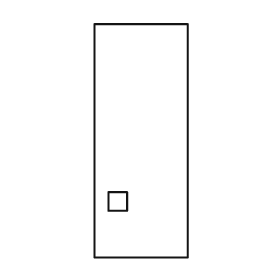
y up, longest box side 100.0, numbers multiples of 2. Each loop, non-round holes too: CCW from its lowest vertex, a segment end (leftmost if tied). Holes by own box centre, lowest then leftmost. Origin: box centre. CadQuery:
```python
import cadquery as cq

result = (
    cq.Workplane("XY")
    .moveTo(-20.0, -50.0)
    .lineTo(20.0, -50.0)
    .lineTo(20.0, 50.0)
    .lineTo(-20.0, 50.0)
    .close()
    .moveTo(-14.0, -30.0)
    .lineTo(-6.0, -30.0)
    .lineTo(-6.0, -22.0)
    .lineTo(-14.0, -22.0)
    .close()
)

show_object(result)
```